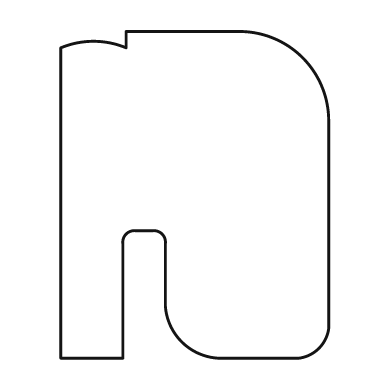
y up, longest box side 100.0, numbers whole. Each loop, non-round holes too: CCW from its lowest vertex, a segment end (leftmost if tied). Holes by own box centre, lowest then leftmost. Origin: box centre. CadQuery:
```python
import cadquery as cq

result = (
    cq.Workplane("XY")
    .moveTo(-41.0, -50.0)
    .lineTo(-22.0, -50.0)
    .lineTo(-22.0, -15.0)
    .threePointArc((-21.0, -12.0), (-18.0, -11.0))
    .lineTo(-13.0, -11.0)
    .threePointArc((-10.0, -12.0), (-9.0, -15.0))
    .lineTo(-9.0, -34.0)
    .threePointArc((-4.0, -45.0), (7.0, -50.0))
    .lineTo(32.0, -50.0)
    .threePointArc((38.0, -47.0), (41.0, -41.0))
    .lineTo(41.0, 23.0)
    .threePointArc((33.0, 42.0), (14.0, 50.0))
    .lineTo(-21.0, 50.0)
    .lineTo(-21.0, 45.0)
    .threePointArc((-31.0, 47.0), (-41.0, 45.0))
    .close()
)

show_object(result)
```